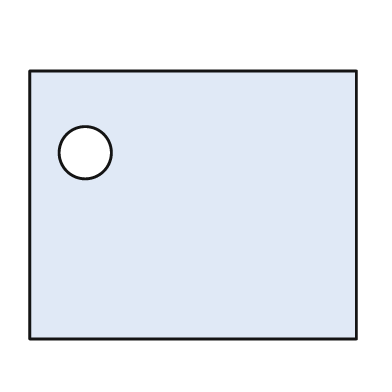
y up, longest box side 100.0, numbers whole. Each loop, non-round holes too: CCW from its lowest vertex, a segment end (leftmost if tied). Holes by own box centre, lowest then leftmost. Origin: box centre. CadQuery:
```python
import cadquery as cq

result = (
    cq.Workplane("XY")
    .moveTo(-50.0, -41.0)
    .lineTo(50.0, -41.0)
    .lineTo(50.0, 41.0)
    .lineTo(-50.0, 41.0)
    .close()
    .moveTo(-33.0, 16.0)
    .circle(8.0)
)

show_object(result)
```